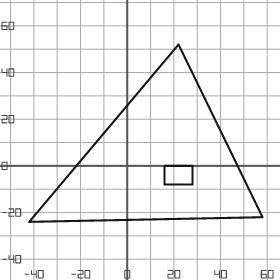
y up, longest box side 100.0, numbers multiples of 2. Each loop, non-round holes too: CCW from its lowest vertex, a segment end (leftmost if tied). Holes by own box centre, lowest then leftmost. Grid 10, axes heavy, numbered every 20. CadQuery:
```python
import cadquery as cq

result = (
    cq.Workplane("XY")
    .moveTo(-42.0, -24.0)
    .lineTo(58.0, -22.0)
    .lineTo(22.0, 52.0)
    .close()
    .moveTo(16.0, -8.0)
    .lineTo(28.0, -8.0)
    .lineTo(28.0, 0.0)
    .lineTo(16.0, 0.0)
    .close()
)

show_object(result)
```